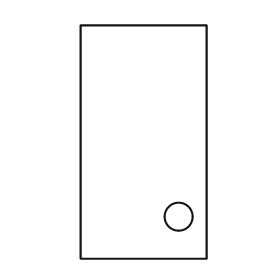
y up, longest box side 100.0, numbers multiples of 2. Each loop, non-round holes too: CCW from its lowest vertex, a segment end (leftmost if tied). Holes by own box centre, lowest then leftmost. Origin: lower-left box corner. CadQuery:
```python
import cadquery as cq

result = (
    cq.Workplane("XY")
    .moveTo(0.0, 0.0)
    .lineTo(54.0, 0.0)
    .lineTo(54.0, 100.0)
    .lineTo(0.0, 100.0)
    .close()
    .moveTo(42.0, 18.0)
    .circle(6.0)
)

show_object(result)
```